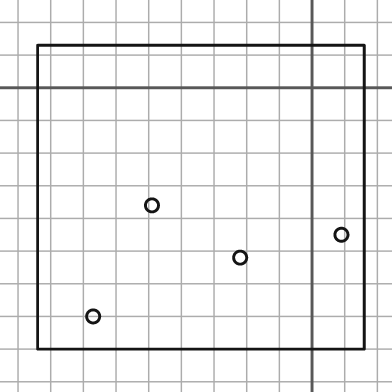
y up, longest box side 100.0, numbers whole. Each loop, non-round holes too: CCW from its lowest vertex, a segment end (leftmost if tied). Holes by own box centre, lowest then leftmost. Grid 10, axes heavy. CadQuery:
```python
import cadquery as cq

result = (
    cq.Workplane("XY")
    .moveTo(-84.0, -80.0)
    .lineTo(16.0, -80.0)
    .lineTo(16.0, 13.0)
    .lineTo(-84.0, 13.0)
    .close()
    .moveTo(-67.0, -70.0)
    .circle(2.0)
    .moveTo(-22.0, -52.0)
    .circle(2.0)
    .moveTo(9.0, -45.0)
    .circle(2.0)
    .moveTo(-49.0, -36.0)
    .circle(2.0)
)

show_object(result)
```